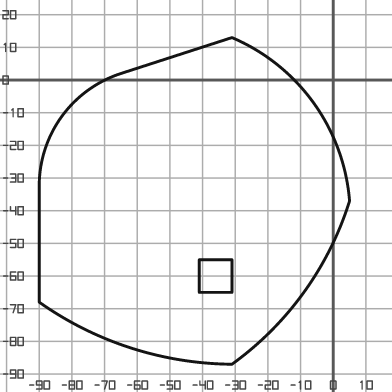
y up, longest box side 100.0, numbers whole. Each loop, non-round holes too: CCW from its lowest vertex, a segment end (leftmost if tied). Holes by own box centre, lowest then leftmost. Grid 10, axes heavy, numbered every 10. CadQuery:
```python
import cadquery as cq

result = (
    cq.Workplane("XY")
    .moveTo(-31.0, -87.0)
    .threePointArc((-9.0, -65.0), (5.0, -37.0))
    .threePointArc((-6.0, -7.0), (-31.0, 13.0))
    .lineTo(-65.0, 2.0)
    .threePointArc((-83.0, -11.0), (-90.0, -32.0))
    .lineTo(-90.0, -68.0)
    .threePointArc((-62.0, -82.0), (-31.0, -87.0))
    .close()
    .moveTo(-41.0, -65.0)
    .lineTo(-31.0, -65.0)
    .lineTo(-31.0, -55.0)
    .lineTo(-41.0, -55.0)
    .close()
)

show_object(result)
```